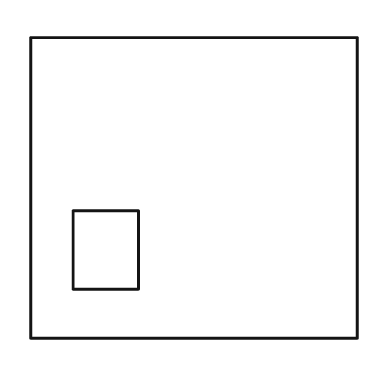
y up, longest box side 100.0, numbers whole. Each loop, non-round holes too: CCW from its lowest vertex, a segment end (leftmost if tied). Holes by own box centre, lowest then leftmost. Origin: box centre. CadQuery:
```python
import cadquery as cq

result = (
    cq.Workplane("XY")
    .moveTo(-50.0, -46.0)
    .lineTo(50.0, -46.0)
    .lineTo(50.0, 46.0)
    .lineTo(-50.0, 46.0)
    .close()
    .moveTo(-37.0, -31.0)
    .lineTo(-17.0, -31.0)
    .lineTo(-17.0, -7.0)
    .lineTo(-37.0, -7.0)
    .close()
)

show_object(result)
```